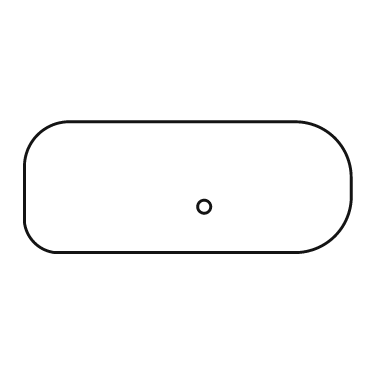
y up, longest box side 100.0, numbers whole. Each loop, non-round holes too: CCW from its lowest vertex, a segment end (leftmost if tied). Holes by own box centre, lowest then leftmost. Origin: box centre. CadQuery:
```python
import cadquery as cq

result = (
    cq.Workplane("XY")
    .moveTo(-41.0, -20.0)
    .lineTo(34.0, -20.0)
    .threePointArc((45.0, -15.0), (50.0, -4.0))
    .lineTo(50.0, 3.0)
    .threePointArc((45.0, 15.0), (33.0, 20.0))
    .lineTo(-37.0, 20.0)
    .threePointArc((-46.0, 16.0), (-50.0, 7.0))
    .lineTo(-50.0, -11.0)
    .threePointArc((-47.0, -17.0), (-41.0, -20.0))
    .close()
    .moveTo(5.0, -6.0)
    .circle(2.0)
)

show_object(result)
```